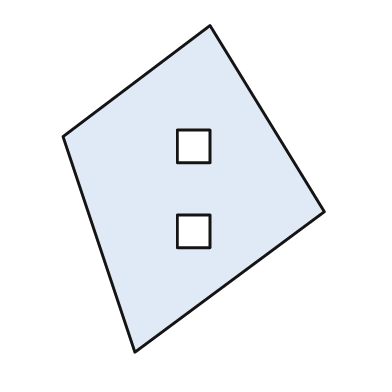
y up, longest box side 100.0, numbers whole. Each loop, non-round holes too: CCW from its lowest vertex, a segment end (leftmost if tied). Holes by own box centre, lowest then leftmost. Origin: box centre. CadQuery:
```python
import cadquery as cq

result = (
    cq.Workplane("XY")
    .moveTo(-18.0, -50.0)
    .lineTo(40.0, -7.0)
    .lineTo(5.0, 50.0)
    .lineTo(-40.0, 16.0)
    .close()
    .moveTo(-5.0, -18.0)
    .lineTo(5.0, -18.0)
    .lineTo(5.0, -8.0)
    .lineTo(-5.0, -8.0)
    .close()
    .moveTo(-5.0, 8.0)
    .lineTo(5.0, 8.0)
    .lineTo(5.0, 18.0)
    .lineTo(-5.0, 18.0)
    .close()
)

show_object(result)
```